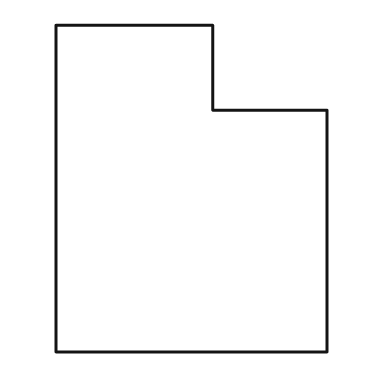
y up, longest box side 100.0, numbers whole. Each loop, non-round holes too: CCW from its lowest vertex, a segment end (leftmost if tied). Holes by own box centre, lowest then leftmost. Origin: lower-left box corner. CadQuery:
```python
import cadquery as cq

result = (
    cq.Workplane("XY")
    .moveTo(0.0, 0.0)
    .lineTo(83.0, 0.0)
    .lineTo(83.0, 74.0)
    .lineTo(48.0, 74.0)
    .lineTo(48.0, 100.0)
    .lineTo(0.0, 100.0)
    .close()
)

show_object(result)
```